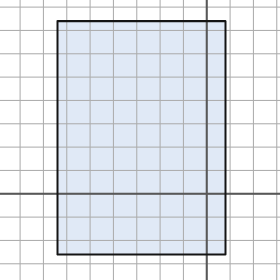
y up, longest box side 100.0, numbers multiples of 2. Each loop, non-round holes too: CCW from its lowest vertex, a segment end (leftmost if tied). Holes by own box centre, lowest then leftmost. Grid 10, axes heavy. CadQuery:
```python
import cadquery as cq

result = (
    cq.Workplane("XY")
    .moveTo(-64.0, -26.0)
    .lineTo(8.0, -26.0)
    .lineTo(8.0, 74.0)
    .lineTo(-64.0, 74.0)
    .close()
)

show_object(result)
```